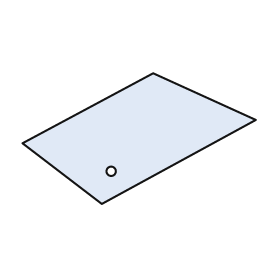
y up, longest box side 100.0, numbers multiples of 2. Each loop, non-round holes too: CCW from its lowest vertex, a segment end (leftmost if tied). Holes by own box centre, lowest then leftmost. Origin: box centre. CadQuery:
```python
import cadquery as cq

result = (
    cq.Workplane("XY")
    .moveTo(-16.0, -28.0)
    .lineTo(50.0, 8.0)
    .lineTo(6.0, 28.0)
    .lineTo(-50.0, -2.0)
    .close()
    .moveTo(-12.0, -14.0)
    .circle(2.0)
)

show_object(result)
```